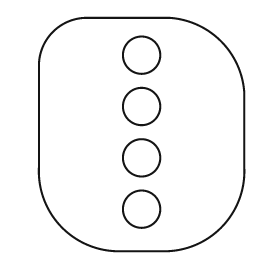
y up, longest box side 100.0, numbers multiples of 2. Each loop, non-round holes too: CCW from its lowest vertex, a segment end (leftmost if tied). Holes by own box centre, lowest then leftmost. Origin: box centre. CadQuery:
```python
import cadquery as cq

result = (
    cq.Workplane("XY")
    .moveTo(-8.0, -50.0)
    .lineTo(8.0, -50.0)
    .threePointArc((34.0, -40.0), (44.0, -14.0))
    .lineTo(44.0, 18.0)
    .threePointArc((34.0, 40.0), (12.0, 50.0))
    .lineTo(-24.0, 50.0)
    .threePointArc((-38.0, 44.0), (-44.0, 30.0))
    .lineTo(-44.0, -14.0)
    .threePointArc((-34.0, -40.0), (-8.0, -50.0))
    .close()
    .moveTo(0.0, -32.0)
    .circle(8.0)
    .moveTo(0.0, -10.0)
    .circle(8.0)
    .moveTo(0.0, 12.0)
    .circle(8.0)
    .moveTo(0.0, 34.0)
    .circle(8.0)
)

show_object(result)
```